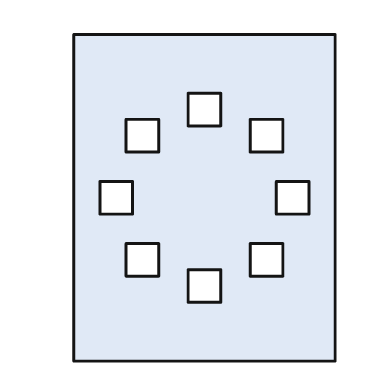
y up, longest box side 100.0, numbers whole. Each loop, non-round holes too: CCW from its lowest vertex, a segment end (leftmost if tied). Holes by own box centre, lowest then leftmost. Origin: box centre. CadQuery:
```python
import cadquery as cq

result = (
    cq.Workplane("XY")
    .moveTo(-40.0, -50.0)
    .lineTo(40.0, -50.0)
    .lineTo(40.0, 50.0)
    .lineTo(-40.0, 50.0)
    .close()
    .moveTo(-5.0, -32.0)
    .lineTo(5.0, -32.0)
    .lineTo(5.0, -22.0)
    .lineTo(-5.0, -22.0)
    .close()
    .moveTo(-24.0, -24.0)
    .lineTo(-14.0, -24.0)
    .lineTo(-14.0, -14.0)
    .lineTo(-24.0, -14.0)
    .close()
    .moveTo(14.0, -24.0)
    .lineTo(24.0, -24.0)
    .lineTo(24.0, -14.0)
    .lineTo(14.0, -14.0)
    .close()
    .moveTo(-32.0, -5.0)
    .lineTo(-22.0, -5.0)
    .lineTo(-22.0, 5.0)
    .lineTo(-32.0, 5.0)
    .close()
    .moveTo(22.0, -5.0)
    .lineTo(32.0, -5.0)
    .lineTo(32.0, 5.0)
    .lineTo(22.0, 5.0)
    .close()
    .moveTo(-24.0, 14.0)
    .lineTo(-14.0, 14.0)
    .lineTo(-14.0, 24.0)
    .lineTo(-24.0, 24.0)
    .close()
    .moveTo(14.0, 14.0)
    .lineTo(24.0, 14.0)
    .lineTo(24.0, 24.0)
    .lineTo(14.0, 24.0)
    .close()
    .moveTo(-5.0, 22.0)
    .lineTo(5.0, 22.0)
    .lineTo(5.0, 32.0)
    .lineTo(-5.0, 32.0)
    .close()
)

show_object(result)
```